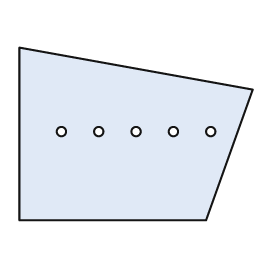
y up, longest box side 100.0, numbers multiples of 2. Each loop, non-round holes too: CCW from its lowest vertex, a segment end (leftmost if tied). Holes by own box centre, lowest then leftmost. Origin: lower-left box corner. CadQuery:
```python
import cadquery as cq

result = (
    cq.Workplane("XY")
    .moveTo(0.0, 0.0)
    .lineTo(80.0, 0.0)
    .lineTo(100.0, 56.0)
    .lineTo(0.0, 74.0)
    .close()
    .moveTo(18.0, 38.0)
    .circle(2.0)
    .moveTo(34.0, 38.0)
    .circle(2.0)
    .moveTo(50.0, 38.0)
    .circle(2.0)
    .moveTo(66.0, 38.0)
    .circle(2.0)
    .moveTo(82.0, 38.0)
    .circle(2.0)
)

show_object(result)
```